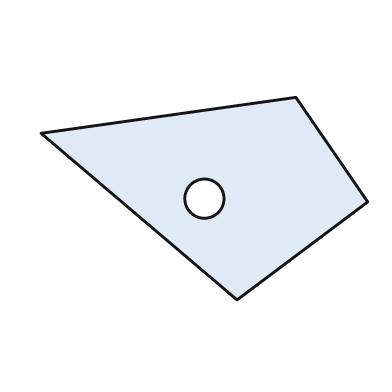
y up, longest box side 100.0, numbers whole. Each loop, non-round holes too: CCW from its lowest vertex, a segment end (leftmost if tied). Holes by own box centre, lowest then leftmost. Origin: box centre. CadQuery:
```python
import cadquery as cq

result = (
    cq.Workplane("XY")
    .moveTo(10.0, -31.0)
    .lineTo(50.0, -1.0)
    .lineTo(28.0, 31.0)
    .lineTo(-50.0, 20.0)
    .close()
    .moveTo(0.0, 0.0)
    .circle(6.0)
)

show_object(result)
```